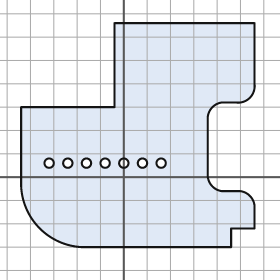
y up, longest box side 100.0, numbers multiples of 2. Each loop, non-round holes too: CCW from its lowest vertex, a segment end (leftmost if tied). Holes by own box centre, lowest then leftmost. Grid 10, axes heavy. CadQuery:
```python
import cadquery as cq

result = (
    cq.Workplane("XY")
    .moveTo(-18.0, -30.0)
    .lineTo(46.0, -30.0)
    .lineTo(46.0, -22.0)
    .lineTo(56.0, -22.0)
    .lineTo(56.0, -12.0)
    .threePointArc((54.0, -8.0), (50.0, -6.0))
    .lineTo(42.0, -6.0)
    .threePointArc((38.0, -4.0), (36.0, 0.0))
    .lineTo(36.0, 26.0)
    .threePointArc((38.0, 30.0), (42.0, 32.0))
    .lineTo(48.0, 32.0)
    .threePointArc((54.0, 34.0), (56.0, 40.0))
    .lineTo(56.0, 66.0)
    .lineTo(-4.0, 66.0)
    .lineTo(-4.0, 30.0)
    .lineTo(-44.0, 30.0)
    .lineTo(-44.0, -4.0)
    .threePointArc((-36.0, -22.0), (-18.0, -30.0))
    .close()
    .moveTo(-32.0, 6.0)
    .circle(2.0)
    .moveTo(-24.0, 6.0)
    .circle(2.0)
    .moveTo(-16.0, 6.0)
    .circle(2.0)
    .moveTo(-8.0, 6.0)
    .circle(2.0)
    .moveTo(0.0, 6.0)
    .circle(2.0)
    .moveTo(8.0, 6.0)
    .circle(2.0)
    .moveTo(16.0, 6.0)
    .circle(2.0)
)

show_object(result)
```